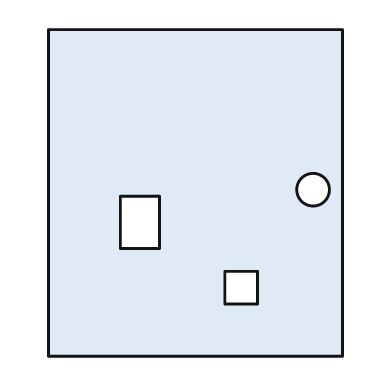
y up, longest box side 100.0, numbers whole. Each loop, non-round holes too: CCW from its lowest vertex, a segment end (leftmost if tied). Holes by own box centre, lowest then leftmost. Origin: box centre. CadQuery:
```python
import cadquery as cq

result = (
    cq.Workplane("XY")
    .moveTo(-45.0, -50.0)
    .lineTo(45.0, -50.0)
    .lineTo(45.0, 50.0)
    .lineTo(-45.0, 50.0)
    .close()
    .moveTo(9.0, -34.0)
    .lineTo(19.0, -34.0)
    .lineTo(19.0, -24.0)
    .lineTo(9.0, -24.0)
    .close()
    .moveTo(-23.0, -17.0)
    .lineTo(-11.0, -17.0)
    .lineTo(-11.0, -1.0)
    .lineTo(-23.0, -1.0)
    .close()
    .moveTo(36.0, 1.0)
    .circle(5.0)
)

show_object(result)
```